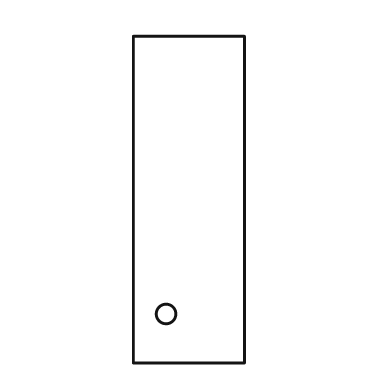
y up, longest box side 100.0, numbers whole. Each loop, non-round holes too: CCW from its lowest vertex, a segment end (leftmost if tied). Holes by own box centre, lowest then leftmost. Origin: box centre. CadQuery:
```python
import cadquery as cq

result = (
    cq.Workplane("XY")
    .moveTo(-17.0, -50.0)
    .lineTo(17.0, -50.0)
    .lineTo(17.0, 50.0)
    .lineTo(-17.0, 50.0)
    .close()
    .moveTo(-7.0, -35.0)
    .circle(3.0)
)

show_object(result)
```